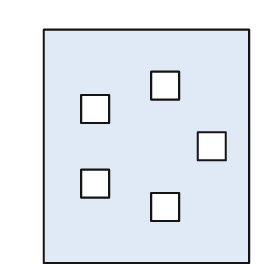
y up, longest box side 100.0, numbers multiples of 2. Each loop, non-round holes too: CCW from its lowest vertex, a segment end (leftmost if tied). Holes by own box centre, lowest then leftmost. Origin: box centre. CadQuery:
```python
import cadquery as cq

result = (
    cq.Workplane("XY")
    .moveTo(-44.0, -50.0)
    .lineTo(44.0, -50.0)
    .lineTo(44.0, 50.0)
    .lineTo(-44.0, 50.0)
    .close()
    .moveTo(2.0, -32.0)
    .lineTo(14.0, -32.0)
    .lineTo(14.0, -20.0)
    .lineTo(2.0, -20.0)
    .close()
    .moveTo(-28.0, -22.0)
    .lineTo(-16.0, -22.0)
    .lineTo(-16.0, -10.0)
    .lineTo(-28.0, -10.0)
    .close()
    .moveTo(22.0, -6.0)
    .lineTo(34.0, -6.0)
    .lineTo(34.0, 6.0)
    .lineTo(22.0, 6.0)
    .close()
    .moveTo(-28.0, 10.0)
    .lineTo(-16.0, 10.0)
    .lineTo(-16.0, 22.0)
    .lineTo(-28.0, 22.0)
    .close()
    .moveTo(2.0, 20.0)
    .lineTo(14.0, 20.0)
    .lineTo(14.0, 32.0)
    .lineTo(2.0, 32.0)
    .close()
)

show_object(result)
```